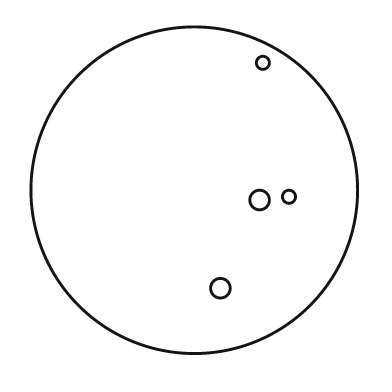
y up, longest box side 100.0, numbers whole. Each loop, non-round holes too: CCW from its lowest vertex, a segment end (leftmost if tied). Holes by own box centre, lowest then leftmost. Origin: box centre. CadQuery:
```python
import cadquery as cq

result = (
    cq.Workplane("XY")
    .moveTo(0.0, 0.0)
    .circle(50.0)
    .moveTo(8.0, -30.0)
    .circle(3.0)
    .moveTo(20.0, -3.0)
    .circle(3.0)
    .moveTo(29.0, -2.0)
    .circle(2.0)
    .moveTo(21.0, 39.0)
    .circle(2.0)
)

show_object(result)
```